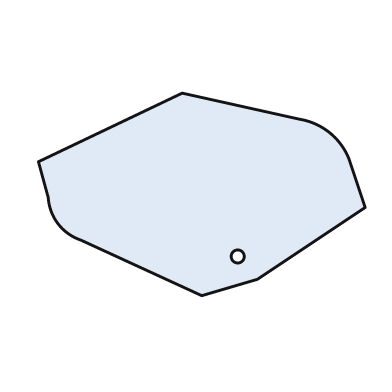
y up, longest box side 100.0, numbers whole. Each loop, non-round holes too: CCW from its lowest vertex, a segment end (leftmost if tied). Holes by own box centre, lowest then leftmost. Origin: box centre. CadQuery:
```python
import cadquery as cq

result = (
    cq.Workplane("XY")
    .moveTo(0.0, -31.0)
    .lineTo(17.0, -26.0)
    .lineTo(50.0, -4.0)
    .lineTo(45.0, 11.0)
    .threePointArc((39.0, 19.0), (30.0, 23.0))
    .lineTo(-6.0, 31.0)
    .lineTo(-50.0, 10.0)
    .lineTo(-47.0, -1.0)
    .threePointArc((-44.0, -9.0), (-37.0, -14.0))
    .close()
    .moveTo(11.0, -19.0)
    .circle(2.0)
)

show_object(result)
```